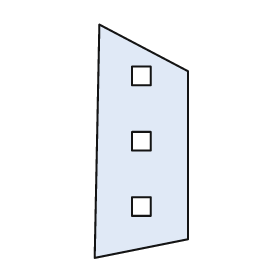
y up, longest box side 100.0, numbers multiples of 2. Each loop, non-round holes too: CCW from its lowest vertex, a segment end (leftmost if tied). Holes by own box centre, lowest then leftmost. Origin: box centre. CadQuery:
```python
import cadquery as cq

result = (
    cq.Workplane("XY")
    .moveTo(-20.0, -50.0)
    .lineTo(20.0, -42.0)
    .lineTo(20.0, 30.0)
    .lineTo(-18.0, 50.0)
    .close()
    .moveTo(-4.0, -32.0)
    .lineTo(4.0, -32.0)
    .lineTo(4.0, -24.0)
    .lineTo(-4.0, -24.0)
    .close()
    .moveTo(-4.0, -4.0)
    .lineTo(4.0, -4.0)
    .lineTo(4.0, 4.0)
    .lineTo(-4.0, 4.0)
    .close()
    .moveTo(-4.0, 24.0)
    .lineTo(4.0, 24.0)
    .lineTo(4.0, 32.0)
    .lineTo(-4.0, 32.0)
    .close()
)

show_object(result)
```